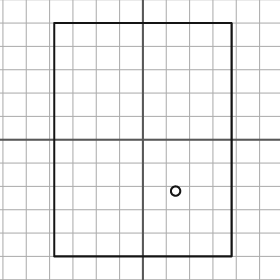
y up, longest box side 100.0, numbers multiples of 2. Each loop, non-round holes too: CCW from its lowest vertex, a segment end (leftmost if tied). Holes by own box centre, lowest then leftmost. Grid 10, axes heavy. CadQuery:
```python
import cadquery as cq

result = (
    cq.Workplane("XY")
    .moveTo(-38.0, -50.0)
    .lineTo(38.0, -50.0)
    .lineTo(38.0, 50.0)
    .lineTo(-38.0, 50.0)
    .close()
    .moveTo(14.0, -22.0)
    .circle(2.0)
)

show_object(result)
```